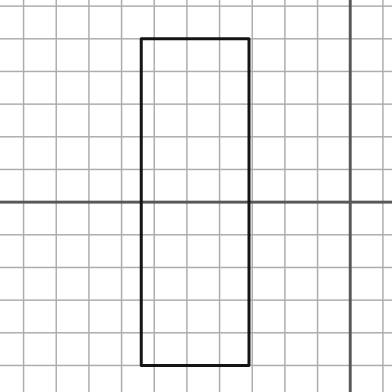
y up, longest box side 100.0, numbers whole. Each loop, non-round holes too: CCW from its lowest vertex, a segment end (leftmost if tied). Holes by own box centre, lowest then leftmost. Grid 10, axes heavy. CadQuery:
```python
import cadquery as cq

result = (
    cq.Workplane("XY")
    .moveTo(-64.0, -50.0)
    .lineTo(-31.0, -50.0)
    .lineTo(-31.0, 50.0)
    .lineTo(-64.0, 50.0)
    .close()
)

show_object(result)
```